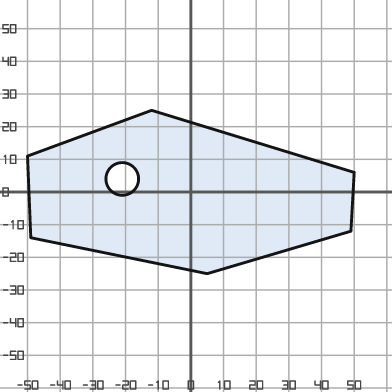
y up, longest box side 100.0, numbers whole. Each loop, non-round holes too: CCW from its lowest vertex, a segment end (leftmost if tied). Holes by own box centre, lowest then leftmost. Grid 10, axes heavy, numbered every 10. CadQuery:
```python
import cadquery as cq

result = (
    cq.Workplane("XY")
    .moveTo(5.0, -25.0)
    .lineTo(49.0, -12.0)
    .lineTo(50.0, 6.0)
    .lineTo(-12.0, 25.0)
    .lineTo(-50.0, 11.0)
    .lineTo(-49.0, -14.0)
    .close()
    .moveTo(-21.0, 4.0)
    .circle(5.0)
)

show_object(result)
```